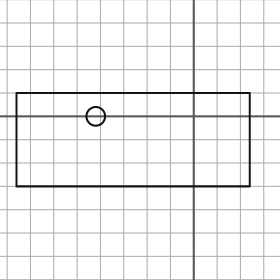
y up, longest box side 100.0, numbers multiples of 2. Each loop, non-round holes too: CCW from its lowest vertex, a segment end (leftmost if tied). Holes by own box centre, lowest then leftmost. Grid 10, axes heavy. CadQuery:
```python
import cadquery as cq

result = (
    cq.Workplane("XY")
    .moveTo(-76.0, -30.0)
    .lineTo(24.0, -30.0)
    .lineTo(24.0, 10.0)
    .lineTo(-76.0, 10.0)
    .close()
    .moveTo(-42.0, 0.0)
    .circle(4.0)
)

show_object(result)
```